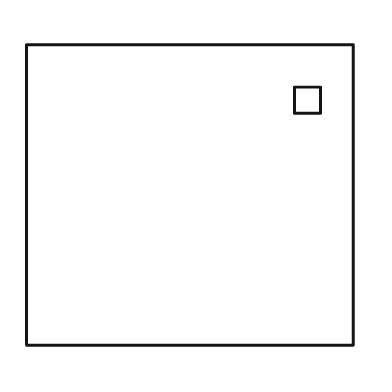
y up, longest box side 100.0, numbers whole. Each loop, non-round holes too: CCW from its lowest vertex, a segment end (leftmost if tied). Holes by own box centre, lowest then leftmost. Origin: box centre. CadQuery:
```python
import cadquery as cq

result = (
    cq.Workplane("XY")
    .moveTo(-50.0, -46.0)
    .lineTo(50.0, -46.0)
    .lineTo(50.0, 46.0)
    .lineTo(-50.0, 46.0)
    .close()
    .moveTo(32.0, 25.0)
    .lineTo(40.0, 25.0)
    .lineTo(40.0, 33.0)
    .lineTo(32.0, 33.0)
    .close()
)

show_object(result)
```